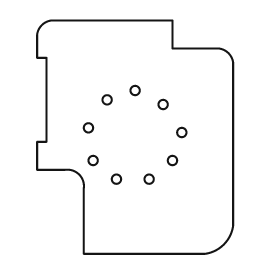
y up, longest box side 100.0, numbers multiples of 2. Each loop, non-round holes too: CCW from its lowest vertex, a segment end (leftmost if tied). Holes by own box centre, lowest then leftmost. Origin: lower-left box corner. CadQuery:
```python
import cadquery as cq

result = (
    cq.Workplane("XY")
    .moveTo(20.0, 0.0)
    .lineTo(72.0, 0.0)
    .threePointArc((80.0, 4.0), (84.0, 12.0))
    .lineTo(84.0, 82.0)
    .threePointArc((82.0, 86.0), (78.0, 88.0))
    .lineTo(58.0, 88.0)
    .lineTo(58.0, 100.0)
    .lineTo(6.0, 100.0)
    .threePointArc((2.0, 98.0), (0.0, 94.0))
    .lineTo(0.0, 84.0)
    .lineTo(4.0, 84.0)
    .lineTo(4.0, 48.0)
    .lineTo(0.0, 48.0)
    .lineTo(0.0, 36.0)
    .lineTo(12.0, 36.0)
    .threePointArc((18.0, 34.0), (20.0, 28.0))
    .close()
    .moveTo(34.0, 32.0)
    .circle(2.0)
    .moveTo(48.0, 32.0)
    .circle(2.0)
    .moveTo(24.0, 40.0)
    .circle(2.0)
    .moveTo(58.0, 40.0)
    .circle(2.0)
    .moveTo(62.0, 52.0)
    .circle(2.0)
    .moveTo(22.0, 54.0)
    .circle(2.0)
    .moveTo(54.0, 64.0)
    .circle(2.0)
    .moveTo(30.0, 66.0)
    .circle(2.0)
    .moveTo(42.0, 70.0)
    .circle(2.0)
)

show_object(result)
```